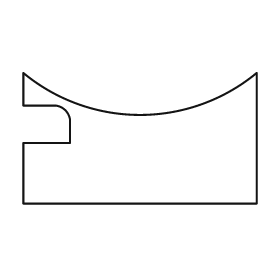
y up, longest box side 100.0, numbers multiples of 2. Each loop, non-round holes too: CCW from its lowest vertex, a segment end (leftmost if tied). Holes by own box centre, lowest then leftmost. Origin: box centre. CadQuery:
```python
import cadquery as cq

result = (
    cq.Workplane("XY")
    .moveTo(-50.0, -28.0)
    .lineTo(50.0, -28.0)
    .lineTo(50.0, 28.0)
    .threePointArc((0.0, 10.0), (-50.0, 28.0))
    .lineTo(-50.0, 14.0)
    .lineTo(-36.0, 14.0)
    .threePointArc((-32.0, 12.0), (-30.0, 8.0))
    .lineTo(-30.0, -2.0)
    .lineTo(-50.0, -2.0)
    .close()
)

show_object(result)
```